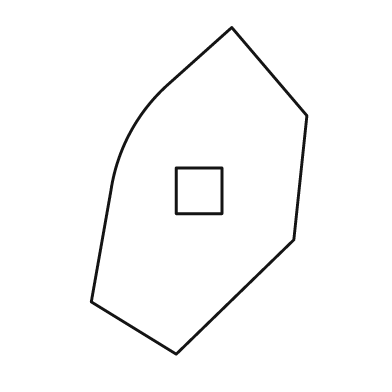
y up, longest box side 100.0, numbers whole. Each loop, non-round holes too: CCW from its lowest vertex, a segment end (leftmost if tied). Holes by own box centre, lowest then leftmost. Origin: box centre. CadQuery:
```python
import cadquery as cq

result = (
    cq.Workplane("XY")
    .moveTo(-7.0, -50.0)
    .lineTo(29.0, -15.0)
    .lineTo(33.0, 23.0)
    .lineTo(10.0, 50.0)
    .lineTo(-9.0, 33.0)
    .threePointArc((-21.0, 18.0), (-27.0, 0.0))
    .lineTo(-33.0, -34.0)
    .close()
    .moveTo(-7.0, -7.0)
    .lineTo(7.0, -7.0)
    .lineTo(7.0, 7.0)
    .lineTo(-7.0, 7.0)
    .close()
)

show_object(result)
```